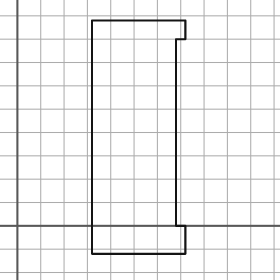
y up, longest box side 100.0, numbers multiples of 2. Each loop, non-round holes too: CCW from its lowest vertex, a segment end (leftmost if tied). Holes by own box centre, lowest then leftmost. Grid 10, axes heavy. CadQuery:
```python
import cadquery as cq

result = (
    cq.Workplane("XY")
    .moveTo(32.0, -12.0)
    .lineTo(72.0, -12.0)
    .lineTo(72.0, 0.0)
    .lineTo(68.0, 0.0)
    .lineTo(68.0, 80.0)
    .lineTo(72.0, 80.0)
    .lineTo(72.0, 88.0)
    .lineTo(32.0, 88.0)
    .close()
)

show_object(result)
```